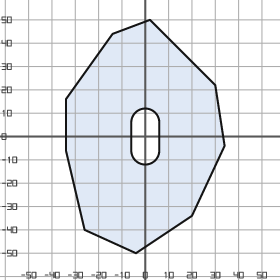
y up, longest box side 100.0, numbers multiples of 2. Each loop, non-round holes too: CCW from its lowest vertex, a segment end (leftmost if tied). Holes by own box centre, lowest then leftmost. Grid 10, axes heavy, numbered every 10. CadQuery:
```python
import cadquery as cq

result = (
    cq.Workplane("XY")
    .moveTo(-4.0, -50.0)
    .lineTo(20.0, -34.0)
    .lineTo(34.0, -4.0)
    .lineTo(30.0, 22.0)
    .lineTo(2.0, 50.0)
    .lineTo(-14.0, 44.0)
    .lineTo(-34.0, 16.0)
    .lineTo(-34.0, -6.0)
    .lineTo(-26.0, -40.0)
    .close()
    .moveTo(-6.0, -6.0)
    .threePointArc((0.0, -12.0), (6.0, -6.0))
    .lineTo(6.0, 6.0)
    .threePointArc((0.0, 12.0), (-6.0, 6.0))
    .close()
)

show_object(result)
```